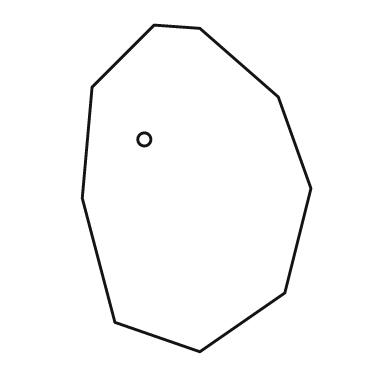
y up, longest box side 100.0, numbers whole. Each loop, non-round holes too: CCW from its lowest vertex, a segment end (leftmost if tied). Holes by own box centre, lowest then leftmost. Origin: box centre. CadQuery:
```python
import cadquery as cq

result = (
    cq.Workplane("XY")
    .moveTo(1.0, -50.0)
    .lineTo(27.0, -32.0)
    .lineTo(35.0, 0.0)
    .lineTo(25.0, 28.0)
    .lineTo(1.0, 49.0)
    .lineTo(-13.0, 50.0)
    .lineTo(-32.0, 31.0)
    .lineTo(-35.0, -3.0)
    .lineTo(-25.0, -41.0)
    .close()
    .moveTo(-16.0, 15.0)
    .circle(2.0)
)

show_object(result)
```